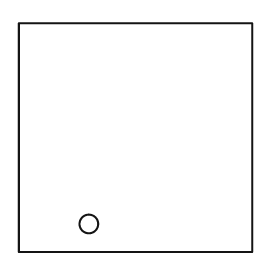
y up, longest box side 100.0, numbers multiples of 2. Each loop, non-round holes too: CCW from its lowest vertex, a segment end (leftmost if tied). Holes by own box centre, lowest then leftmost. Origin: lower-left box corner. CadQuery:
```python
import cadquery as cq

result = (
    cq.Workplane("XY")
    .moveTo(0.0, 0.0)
    .lineTo(100.0, 0.0)
    .lineTo(100.0, 98.0)
    .lineTo(0.0, 98.0)
    .close()
    .moveTo(30.0, 12.0)
    .circle(4.0)
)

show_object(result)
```